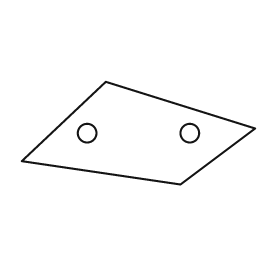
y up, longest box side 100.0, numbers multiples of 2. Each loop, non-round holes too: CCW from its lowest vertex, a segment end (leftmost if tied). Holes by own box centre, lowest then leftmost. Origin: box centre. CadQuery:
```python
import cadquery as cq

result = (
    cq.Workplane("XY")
    .moveTo(18.0, -22.0)
    .lineTo(50.0, 2.0)
    .lineTo(-14.0, 22.0)
    .lineTo(-50.0, -12.0)
    .close()
    .moveTo(-22.0, 0.0)
    .circle(4.0)
    .moveTo(22.0, 0.0)
    .circle(4.0)
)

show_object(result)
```